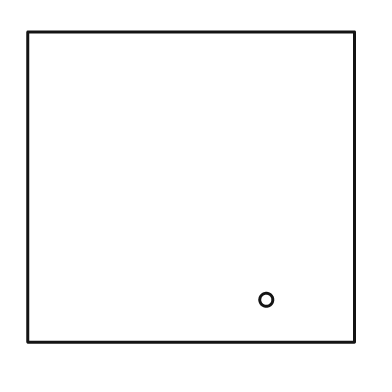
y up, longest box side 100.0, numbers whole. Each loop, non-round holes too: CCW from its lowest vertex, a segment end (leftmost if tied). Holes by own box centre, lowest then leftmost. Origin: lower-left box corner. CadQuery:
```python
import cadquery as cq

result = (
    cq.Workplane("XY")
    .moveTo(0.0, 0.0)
    .lineTo(100.0, 0.0)
    .lineTo(100.0, 95.0)
    .lineTo(0.0, 95.0)
    .close()
    .moveTo(73.0, 13.0)
    .circle(2.0)
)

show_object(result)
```